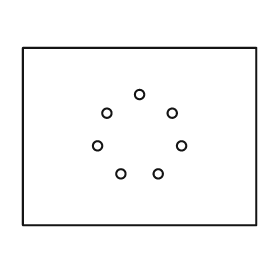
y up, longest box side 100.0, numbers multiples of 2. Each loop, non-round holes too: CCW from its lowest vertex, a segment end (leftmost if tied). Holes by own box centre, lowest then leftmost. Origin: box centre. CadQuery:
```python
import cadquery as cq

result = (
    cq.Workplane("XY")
    .moveTo(-50.0, -38.0)
    .lineTo(50.0, -38.0)
    .lineTo(50.0, 38.0)
    .lineTo(-50.0, 38.0)
    .close()
    .moveTo(-8.0, -16.0)
    .circle(2.0)
    .moveTo(8.0, -16.0)
    .circle(2.0)
    .moveTo(-18.0, -4.0)
    .circle(2.0)
    .moveTo(18.0, -4.0)
    .circle(2.0)
    .moveTo(-14.0, 10.0)
    .circle(2.0)
    .moveTo(14.0, 10.0)
    .circle(2.0)
    .moveTo(0.0, 18.0)
    .circle(2.0)
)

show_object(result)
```